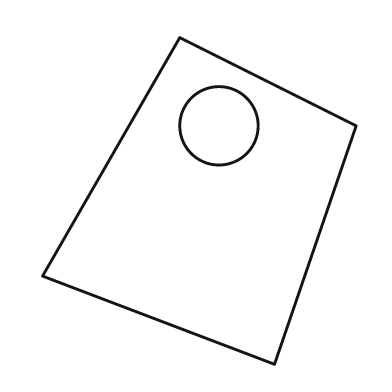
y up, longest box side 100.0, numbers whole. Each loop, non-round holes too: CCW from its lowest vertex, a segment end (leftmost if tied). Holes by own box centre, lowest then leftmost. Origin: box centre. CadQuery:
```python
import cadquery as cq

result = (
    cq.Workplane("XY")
    .moveTo(23.0, -50.0)
    .lineTo(48.0, 23.0)
    .lineTo(-6.0, 50.0)
    .lineTo(-48.0, -23.0)
    .close()
    .moveTo(6.0, 23.0)
    .circle(12.0)
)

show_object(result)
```